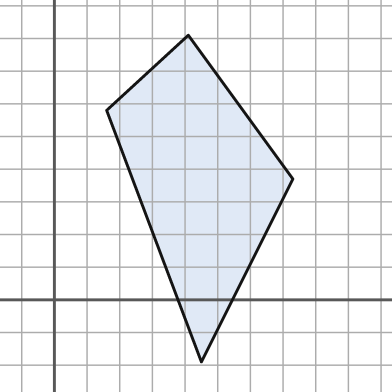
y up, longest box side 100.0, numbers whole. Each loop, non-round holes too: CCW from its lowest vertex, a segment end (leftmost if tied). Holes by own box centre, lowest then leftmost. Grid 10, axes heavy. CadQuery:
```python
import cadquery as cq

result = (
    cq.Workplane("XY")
    .moveTo(45.0, -19.0)
    .lineTo(73.0, 37.0)
    .lineTo(41.0, 81.0)
    .lineTo(16.0, 58.0)
    .close()
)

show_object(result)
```